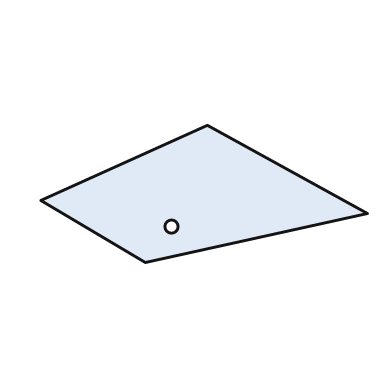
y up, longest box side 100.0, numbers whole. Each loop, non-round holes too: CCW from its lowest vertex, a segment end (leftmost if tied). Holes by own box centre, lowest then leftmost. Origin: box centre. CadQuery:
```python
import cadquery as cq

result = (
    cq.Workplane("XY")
    .moveTo(-18.0, -21.0)
    .lineTo(50.0, -6.0)
    .lineTo(1.0, 21.0)
    .lineTo(-50.0, -2.0)
    .close()
    .moveTo(-10.0, -10.0)
    .circle(2.0)
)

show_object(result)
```